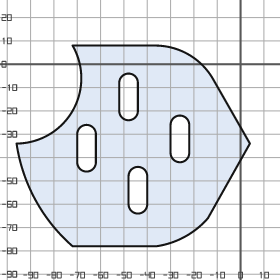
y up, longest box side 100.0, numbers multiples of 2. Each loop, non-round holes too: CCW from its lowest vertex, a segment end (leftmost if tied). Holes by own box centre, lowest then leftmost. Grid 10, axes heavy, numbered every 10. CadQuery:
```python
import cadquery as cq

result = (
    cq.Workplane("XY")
    .moveTo(-72.0, -78.0)
    .lineTo(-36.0, -78.0)
    .threePointArc((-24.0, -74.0), (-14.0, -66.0))
    .lineTo(4.0, -34.0)
    .lineTo(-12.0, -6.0)
    .threePointArc((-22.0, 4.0), (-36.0, 8.0))
    .lineTo(-72.0, 8.0)
    .threePointArc((-72.0, -20.0), (-96.0, -34.0))
    .threePointArc((-88.0, -58.0), (-72.0, -78.0))
    .close()
    .moveTo(-48.0, -60.0)
    .threePointArc((-44.0, -64.0), (-40.0, -60.0))
    .lineTo(-40.0, -48.0)
    .threePointArc((-44.0, -44.0), (-48.0, -48.0))
    .close()
    .moveTo(-70.0, -42.0)
    .threePointArc((-66.0, -46.0), (-62.0, -42.0))
    .lineTo(-62.0, -30.0)
    .threePointArc((-66.0, -26.0), (-70.0, -30.0))
    .close()
    .moveTo(-30.0, -38.0)
    .threePointArc((-26.0, -42.0), (-22.0, -38.0))
    .lineTo(-22.0, -26.0)
    .threePointArc((-26.0, -22.0), (-30.0, -26.0))
    .close()
    .moveTo(-52.0, -20.0)
    .threePointArc((-48.0, -24.0), (-44.0, -20.0))
    .lineTo(-44.0, -8.0)
    .threePointArc((-48.0, -4.0), (-52.0, -8.0))
    .close()
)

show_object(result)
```